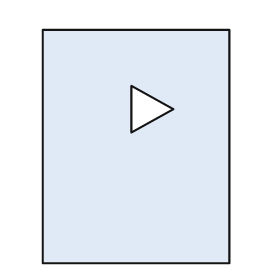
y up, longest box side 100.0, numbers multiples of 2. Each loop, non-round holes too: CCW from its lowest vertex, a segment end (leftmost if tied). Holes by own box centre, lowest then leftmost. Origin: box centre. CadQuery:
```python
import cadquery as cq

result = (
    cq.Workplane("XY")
    .moveTo(-40.0, -50.0)
    .lineTo(40.0, -50.0)
    .lineTo(40.0, 50.0)
    .lineTo(-40.0, 50.0)
    .close()
    .moveTo(-2.0, 6.0)
    .lineTo(16.0, 16.0)
    .lineTo(-2.0, 26.0)
    .close()
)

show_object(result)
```